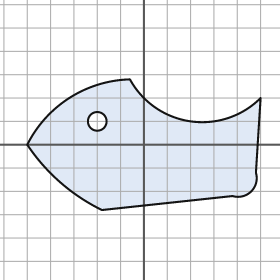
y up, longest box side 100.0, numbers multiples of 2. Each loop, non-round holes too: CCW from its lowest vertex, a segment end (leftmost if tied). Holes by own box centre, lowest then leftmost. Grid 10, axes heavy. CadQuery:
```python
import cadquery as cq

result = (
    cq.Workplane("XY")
    .moveTo(-18.0, -28.0)
    .lineTo(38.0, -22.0)
    .threePointArc((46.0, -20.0), (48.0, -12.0))
    .lineTo(50.0, 20.0)
    .threePointArc((20.0, 10.0), (-6.0, 28.0))
    .threePointArc((-32.0, 20.0), (-50.0, 0.0))
    .threePointArc((-36.0, -16.0), (-18.0, -28.0))
    .close()
    .moveTo(-20.0, 10.0)
    .circle(4.0)
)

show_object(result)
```